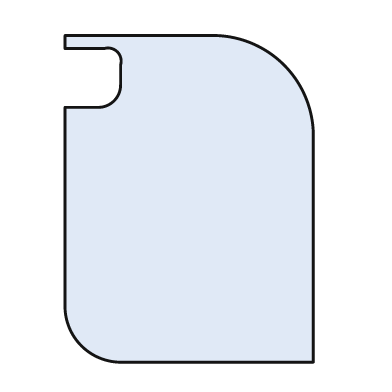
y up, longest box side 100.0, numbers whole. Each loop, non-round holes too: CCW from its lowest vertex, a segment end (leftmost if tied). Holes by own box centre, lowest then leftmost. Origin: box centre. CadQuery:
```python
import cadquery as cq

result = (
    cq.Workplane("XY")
    .moveTo(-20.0, -50.0)
    .lineTo(38.0, -50.0)
    .lineTo(38.0, 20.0)
    .threePointArc((29.0, 41.0), (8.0, 50.0))
    .lineTo(-38.0, 50.0)
    .lineTo(-38.0, 46.0)
    .lineTo(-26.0, 46.0)
    .threePointArc((-22.0, 45.0), (-21.0, 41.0))
    .lineTo(-21.0, 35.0)
    .threePointArc((-23.0, 30.0), (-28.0, 28.0))
    .lineTo(-38.0, 28.0)
    .lineTo(-38.0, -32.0)
    .threePointArc((-33.0, -45.0), (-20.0, -50.0))
    .close()
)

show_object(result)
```